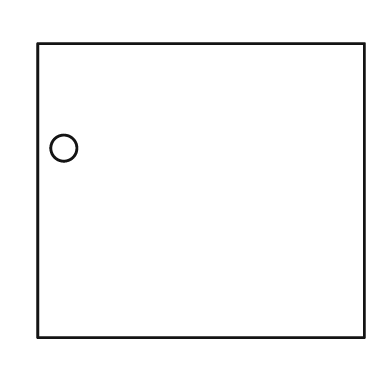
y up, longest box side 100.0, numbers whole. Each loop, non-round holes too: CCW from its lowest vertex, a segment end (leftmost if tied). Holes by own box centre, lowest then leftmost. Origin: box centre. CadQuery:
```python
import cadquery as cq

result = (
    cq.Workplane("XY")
    .moveTo(-50.0, -45.0)
    .lineTo(50.0, -45.0)
    .lineTo(50.0, 45.0)
    .lineTo(-50.0, 45.0)
    .close()
    .moveTo(-42.0, 13.0)
    .circle(4.0)
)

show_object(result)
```